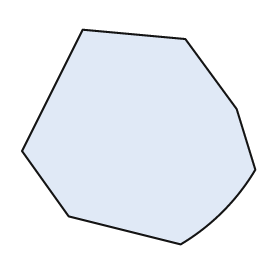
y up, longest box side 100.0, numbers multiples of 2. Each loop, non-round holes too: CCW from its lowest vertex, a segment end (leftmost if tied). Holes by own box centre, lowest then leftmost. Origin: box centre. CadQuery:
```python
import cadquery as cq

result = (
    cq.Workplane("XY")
    .moveTo(18.0, -46.0)
    .threePointArc((36.0, -32.0), (50.0, -14.0))
    .lineTo(42.0, 12.0)
    .lineTo(20.0, 42.0)
    .lineTo(-24.0, 46.0)
    .lineTo(-50.0, -6.0)
    .lineTo(-30.0, -34.0)
    .close()
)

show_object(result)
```